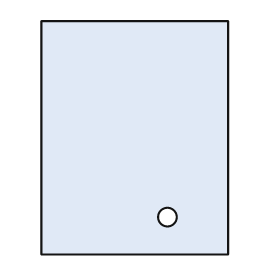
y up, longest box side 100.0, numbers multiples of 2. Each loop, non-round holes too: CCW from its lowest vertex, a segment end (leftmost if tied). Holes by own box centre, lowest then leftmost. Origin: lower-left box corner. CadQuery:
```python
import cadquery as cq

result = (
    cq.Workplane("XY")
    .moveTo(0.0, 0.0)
    .lineTo(80.0, 0.0)
    .lineTo(80.0, 100.0)
    .lineTo(0.0, 100.0)
    .close()
    .moveTo(54.0, 16.0)
    .circle(4.0)
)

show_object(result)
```